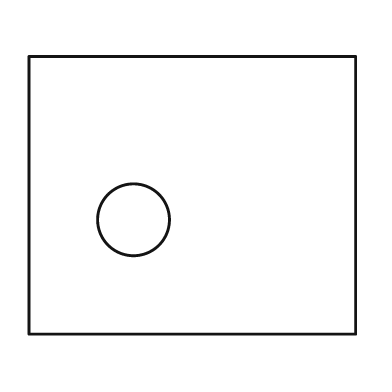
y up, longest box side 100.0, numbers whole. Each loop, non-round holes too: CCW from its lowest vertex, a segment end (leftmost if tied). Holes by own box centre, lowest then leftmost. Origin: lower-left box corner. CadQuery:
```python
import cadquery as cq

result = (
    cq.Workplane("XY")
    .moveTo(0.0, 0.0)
    .lineTo(100.0, 0.0)
    .lineTo(100.0, 85.0)
    .lineTo(0.0, 85.0)
    .close()
    .moveTo(32.0, 35.0)
    .circle(11.0)
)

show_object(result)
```